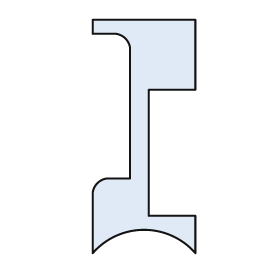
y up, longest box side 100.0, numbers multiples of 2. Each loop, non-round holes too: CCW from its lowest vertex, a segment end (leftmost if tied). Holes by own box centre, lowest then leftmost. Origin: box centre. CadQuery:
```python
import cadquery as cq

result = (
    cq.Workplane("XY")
    .moveTo(-22.0, -50.0)
    .threePointArc((0.0, -40.0), (22.0, -50.0))
    .lineTo(22.0, -34.0)
    .lineTo(2.0, -34.0)
    .lineTo(2.0, 20.0)
    .lineTo(22.0, 20.0)
    .lineTo(22.0, 50.0)
    .lineTo(-22.0, 50.0)
    .lineTo(-22.0, 44.0)
    .lineTo(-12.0, 44.0)
    .threePointArc((-8.0, 42.0), (-6.0, 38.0))
    .lineTo(-6.0, -18.0)
    .lineTo(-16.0, -18.0)
    .threePointArc((-20.0, -20.0), (-22.0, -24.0))
    .close()
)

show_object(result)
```